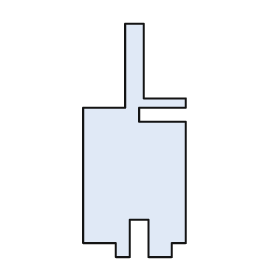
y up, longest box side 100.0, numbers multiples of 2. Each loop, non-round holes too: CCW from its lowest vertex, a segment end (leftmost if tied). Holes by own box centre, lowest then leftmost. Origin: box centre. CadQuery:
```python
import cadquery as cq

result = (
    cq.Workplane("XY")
    .moveTo(-8.0, -50.0)
    .lineTo(-2.0, -50.0)
    .lineTo(-2.0, -34.0)
    .lineTo(6.0, -34.0)
    .lineTo(6.0, -50.0)
    .lineTo(16.0, -50.0)
    .lineTo(16.0, -44.0)
    .lineTo(22.0, -44.0)
    .lineTo(22.0, 8.0)
    .lineTo(2.0, 8.0)
    .lineTo(2.0, 14.0)
    .lineTo(22.0, 14.0)
    .lineTo(22.0, 18.0)
    .lineTo(4.0, 18.0)
    .lineTo(4.0, 50.0)
    .lineTo(-4.0, 50.0)
    .lineTo(-4.0, 14.0)
    .lineTo(-22.0, 14.0)
    .lineTo(-22.0, -44.0)
    .lineTo(-8.0, -44.0)
    .close()
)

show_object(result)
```